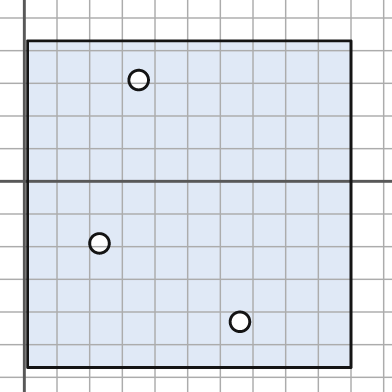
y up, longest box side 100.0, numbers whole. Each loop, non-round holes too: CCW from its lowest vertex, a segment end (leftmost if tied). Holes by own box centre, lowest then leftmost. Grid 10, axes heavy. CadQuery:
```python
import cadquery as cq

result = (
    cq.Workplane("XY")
    .moveTo(1.0, -57.0)
    .lineTo(100.0, -57.0)
    .lineTo(100.0, 43.0)
    .lineTo(1.0, 43.0)
    .close()
    .moveTo(66.0, -43.0)
    .circle(3.0)
    .moveTo(23.0, -19.0)
    .circle(3.0)
    .moveTo(35.0, 31.0)
    .circle(3.0)
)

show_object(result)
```